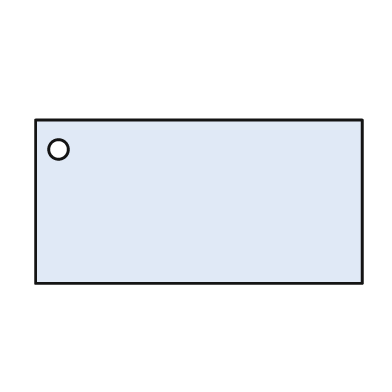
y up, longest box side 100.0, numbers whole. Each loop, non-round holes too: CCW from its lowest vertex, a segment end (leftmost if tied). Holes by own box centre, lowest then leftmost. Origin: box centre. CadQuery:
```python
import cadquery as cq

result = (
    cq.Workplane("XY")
    .moveTo(-50.0, -25.0)
    .lineTo(50.0, -25.0)
    .lineTo(50.0, 25.0)
    .lineTo(-50.0, 25.0)
    .close()
    .moveTo(-43.0, 16.0)
    .circle(3.0)
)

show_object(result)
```